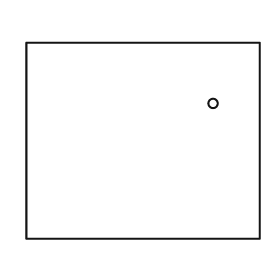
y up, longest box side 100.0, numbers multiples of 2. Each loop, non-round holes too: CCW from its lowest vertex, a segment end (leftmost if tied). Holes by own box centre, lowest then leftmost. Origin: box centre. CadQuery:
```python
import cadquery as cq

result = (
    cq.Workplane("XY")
    .moveTo(-50.0, -42.0)
    .lineTo(50.0, -42.0)
    .lineTo(50.0, 42.0)
    .lineTo(-50.0, 42.0)
    .close()
    .moveTo(30.0, 16.0)
    .circle(2.0)
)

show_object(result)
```